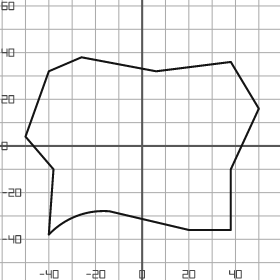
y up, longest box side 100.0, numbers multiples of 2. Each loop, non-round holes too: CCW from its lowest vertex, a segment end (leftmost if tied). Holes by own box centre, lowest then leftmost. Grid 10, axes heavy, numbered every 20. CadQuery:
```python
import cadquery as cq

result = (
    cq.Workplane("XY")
    .moveTo(-40.0, -38.0)
    .threePointArc((-28.0, -30.0), (-14.0, -28.0))
    .lineTo(20.0, -36.0)
    .lineTo(38.0, -36.0)
    .lineTo(38.0, -10.0)
    .lineTo(50.0, 16.0)
    .lineTo(38.0, 36.0)
    .lineTo(6.0, 32.0)
    .lineTo(-26.0, 38.0)
    .lineTo(-40.0, 32.0)
    .lineTo(-50.0, 4.0)
    .lineTo(-38.0, -10.0)
    .close()
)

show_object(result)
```